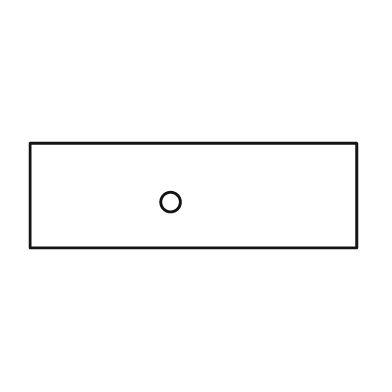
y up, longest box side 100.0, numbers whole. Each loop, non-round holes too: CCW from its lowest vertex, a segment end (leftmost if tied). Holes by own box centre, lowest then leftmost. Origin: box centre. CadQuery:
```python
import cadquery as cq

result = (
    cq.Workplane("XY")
    .moveTo(-50.0, -16.0)
    .lineTo(50.0, -16.0)
    .lineTo(50.0, 16.0)
    .lineTo(-50.0, 16.0)
    .close()
    .moveTo(-7.0, -2.0)
    .circle(3.0)
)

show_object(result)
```